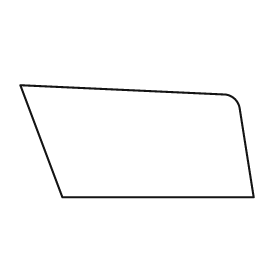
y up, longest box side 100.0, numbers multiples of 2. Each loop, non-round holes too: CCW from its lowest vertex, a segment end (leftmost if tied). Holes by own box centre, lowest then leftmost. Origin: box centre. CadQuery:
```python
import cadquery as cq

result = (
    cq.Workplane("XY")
    .moveTo(-32.0, -24.0)
    .lineTo(50.0, -24.0)
    .lineTo(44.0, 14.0)
    .threePointArc((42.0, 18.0), (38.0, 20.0))
    .lineTo(-50.0, 24.0)
    .close()
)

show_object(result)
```